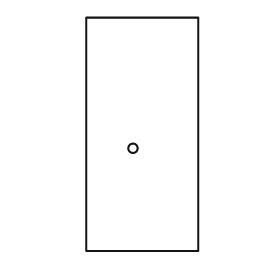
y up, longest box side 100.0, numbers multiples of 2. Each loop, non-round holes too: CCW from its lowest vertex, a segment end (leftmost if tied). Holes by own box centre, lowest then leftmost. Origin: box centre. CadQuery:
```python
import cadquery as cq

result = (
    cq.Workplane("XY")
    .moveTo(-24.0, -50.0)
    .lineTo(24.0, -50.0)
    .lineTo(24.0, 50.0)
    .lineTo(-24.0, 50.0)
    .close()
    .moveTo(-4.0, -6.0)
    .circle(2.0)
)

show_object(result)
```